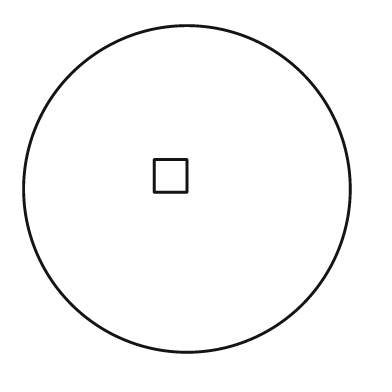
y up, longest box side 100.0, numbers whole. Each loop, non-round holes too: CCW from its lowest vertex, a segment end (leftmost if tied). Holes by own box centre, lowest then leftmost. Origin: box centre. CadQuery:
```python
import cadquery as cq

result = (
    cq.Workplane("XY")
    .moveTo(0.0, 0.0)
    .circle(50.0)
    .moveTo(-10.0, -1.0)
    .lineTo(0.0, -1.0)
    .lineTo(0.0, 9.0)
    .lineTo(-10.0, 9.0)
    .close()
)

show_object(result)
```